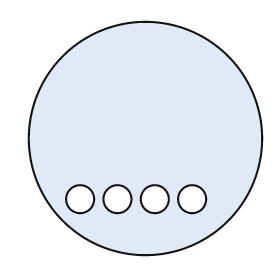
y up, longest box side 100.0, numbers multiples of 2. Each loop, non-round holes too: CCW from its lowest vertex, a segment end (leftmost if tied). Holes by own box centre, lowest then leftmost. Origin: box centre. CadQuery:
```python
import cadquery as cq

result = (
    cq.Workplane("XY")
    .moveTo(0.0, 0.0)
    .circle(50.0)
    .moveTo(-28.0, -26.0)
    .circle(6.0)
    .moveTo(-12.0, -26.0)
    .circle(6.0)
    .moveTo(4.0, -26.0)
    .circle(6.0)
    .moveTo(20.0, -26.0)
    .circle(6.0)
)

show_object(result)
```